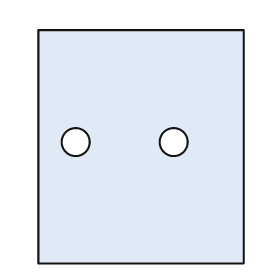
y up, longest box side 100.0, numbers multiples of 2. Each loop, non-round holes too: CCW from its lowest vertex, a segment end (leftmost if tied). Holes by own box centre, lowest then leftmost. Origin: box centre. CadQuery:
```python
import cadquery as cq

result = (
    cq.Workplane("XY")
    .moveTo(-44.0, -50.0)
    .lineTo(44.0, -50.0)
    .lineTo(44.0, 50.0)
    .lineTo(-44.0, 50.0)
    .close()
    .moveTo(-28.0, 2.0)
    .circle(6.0)
    .moveTo(14.0, 2.0)
    .circle(6.0)
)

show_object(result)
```